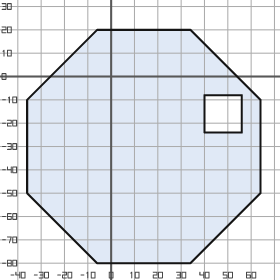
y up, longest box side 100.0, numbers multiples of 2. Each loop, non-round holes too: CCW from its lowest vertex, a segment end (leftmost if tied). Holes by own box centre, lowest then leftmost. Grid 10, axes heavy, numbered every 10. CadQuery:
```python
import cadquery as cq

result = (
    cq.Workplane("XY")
    .moveTo(-6.0, -80.0)
    .lineTo(34.0, -80.0)
    .lineTo(64.0, -50.0)
    .lineTo(64.0, -10.0)
    .lineTo(34.0, 20.0)
    .lineTo(-6.0, 20.0)
    .lineTo(-36.0, -10.0)
    .lineTo(-36.0, -50.0)
    .close()
    .moveTo(40.0, -24.0)
    .lineTo(56.0, -24.0)
    .lineTo(56.0, -8.0)
    .lineTo(40.0, -8.0)
    .close()
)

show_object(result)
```